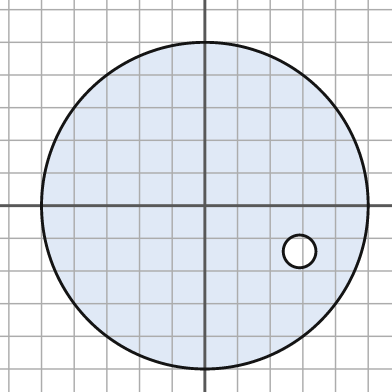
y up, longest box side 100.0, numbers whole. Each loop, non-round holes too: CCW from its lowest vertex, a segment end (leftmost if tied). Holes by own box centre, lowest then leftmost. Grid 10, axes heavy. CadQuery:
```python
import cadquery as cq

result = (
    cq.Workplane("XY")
    .moveTo(0.0, 0.0)
    .circle(50.0)
    .moveTo(29.0, -14.0)
    .circle(5.0)
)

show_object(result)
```